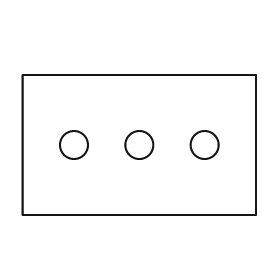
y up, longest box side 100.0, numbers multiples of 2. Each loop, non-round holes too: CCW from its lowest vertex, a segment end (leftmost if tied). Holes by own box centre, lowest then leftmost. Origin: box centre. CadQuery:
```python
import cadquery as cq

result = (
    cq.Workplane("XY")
    .moveTo(-50.0, -30.0)
    .lineTo(50.0, -30.0)
    .lineTo(50.0, 30.0)
    .lineTo(-50.0, 30.0)
    .close()
    .moveTo(-28.0, 0.0)
    .circle(6.0)
    .moveTo(0.0, 0.0)
    .circle(6.0)
    .moveTo(28.0, 0.0)
    .circle(6.0)
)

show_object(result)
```